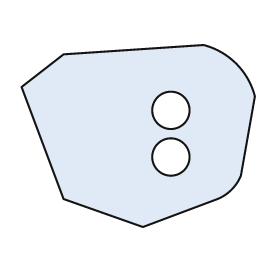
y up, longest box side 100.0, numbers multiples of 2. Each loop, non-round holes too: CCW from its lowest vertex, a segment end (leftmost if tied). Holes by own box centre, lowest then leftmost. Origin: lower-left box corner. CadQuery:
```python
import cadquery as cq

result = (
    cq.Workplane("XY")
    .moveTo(52.0, 0.0)
    .lineTo(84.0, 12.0)
    .threePointArc((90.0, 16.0), (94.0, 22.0))
    .lineTo(100.0, 56.0)
    .threePointArc((92.0, 70.0), (78.0, 78.0))
    .lineTo(18.0, 74.0)
    .lineTo(0.0, 60.0)
    .lineTo(18.0, 12.0)
    .close()
    .moveTo(64.0, 30.0)
    .circle(8.0)
    .moveTo(64.0, 50.0)
    .circle(8.0)
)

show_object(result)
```